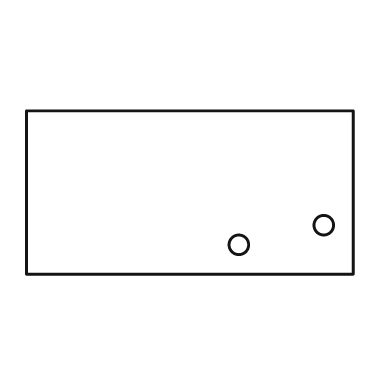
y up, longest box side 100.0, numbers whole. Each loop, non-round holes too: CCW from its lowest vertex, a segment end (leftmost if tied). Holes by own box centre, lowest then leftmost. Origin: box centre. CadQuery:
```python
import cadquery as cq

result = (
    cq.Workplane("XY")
    .moveTo(-50.0, -25.0)
    .lineTo(50.0, -25.0)
    .lineTo(50.0, 25.0)
    .lineTo(-50.0, 25.0)
    .close()
    .moveTo(15.0, -16.0)
    .circle(3.0)
    .moveTo(41.0, -10.0)
    .circle(3.0)
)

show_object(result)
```